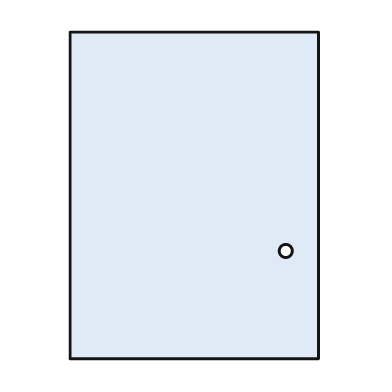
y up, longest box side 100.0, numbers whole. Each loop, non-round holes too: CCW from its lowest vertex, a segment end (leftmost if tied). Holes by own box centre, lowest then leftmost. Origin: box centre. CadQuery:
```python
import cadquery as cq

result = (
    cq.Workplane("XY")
    .moveTo(-38.0, -50.0)
    .lineTo(38.0, -50.0)
    .lineTo(38.0, 50.0)
    .lineTo(-38.0, 50.0)
    .close()
    .moveTo(28.0, -17.0)
    .circle(2.0)
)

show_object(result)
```